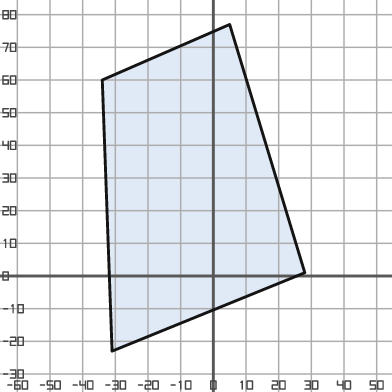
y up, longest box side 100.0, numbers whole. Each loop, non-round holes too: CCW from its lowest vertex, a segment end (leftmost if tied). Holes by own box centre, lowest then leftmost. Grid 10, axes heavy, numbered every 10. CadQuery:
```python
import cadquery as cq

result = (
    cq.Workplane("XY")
    .moveTo(-31.0, -23.0)
    .lineTo(28.0, 1.0)
    .lineTo(5.0, 77.0)
    .lineTo(-34.0, 60.0)
    .close()
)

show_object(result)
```